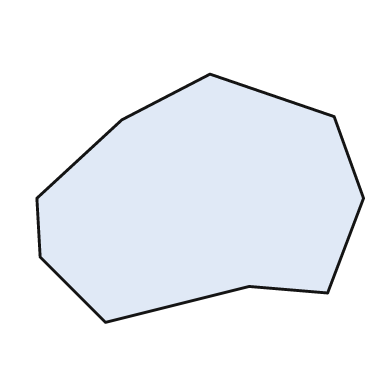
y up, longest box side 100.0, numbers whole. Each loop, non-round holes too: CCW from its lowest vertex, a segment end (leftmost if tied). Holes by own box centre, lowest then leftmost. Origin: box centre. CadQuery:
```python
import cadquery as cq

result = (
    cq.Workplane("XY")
    .moveTo(-29.0, -38.0)
    .lineTo(15.0, -27.0)
    .lineTo(39.0, -29.0)
    .lineTo(50.0, 0.0)
    .lineTo(41.0, 25.0)
    .lineTo(3.0, 38.0)
    .lineTo(-24.0, 24.0)
    .lineTo(-50.0, 0.0)
    .lineTo(-49.0, -18.0)
    .close()
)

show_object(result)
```